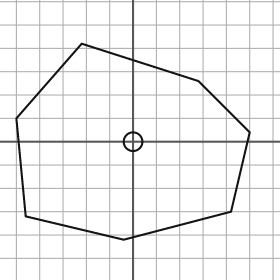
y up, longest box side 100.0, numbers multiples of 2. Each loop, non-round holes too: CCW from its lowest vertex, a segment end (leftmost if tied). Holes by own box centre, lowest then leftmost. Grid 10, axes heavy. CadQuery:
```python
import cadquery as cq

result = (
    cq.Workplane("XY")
    .moveTo(-4.0, -42.0)
    .lineTo(42.0, -30.0)
    .lineTo(50.0, 4.0)
    .lineTo(28.0, 26.0)
    .lineTo(-22.0, 42.0)
    .lineTo(-50.0, 10.0)
    .lineTo(-46.0, -32.0)
    .close()
    .moveTo(0.0, 0.0)
    .circle(4.0)
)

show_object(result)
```